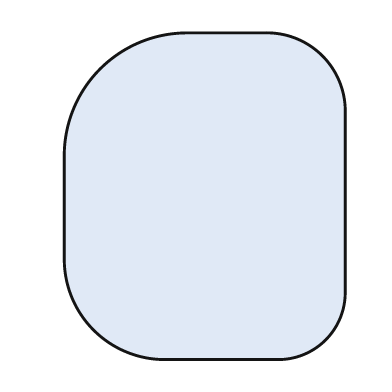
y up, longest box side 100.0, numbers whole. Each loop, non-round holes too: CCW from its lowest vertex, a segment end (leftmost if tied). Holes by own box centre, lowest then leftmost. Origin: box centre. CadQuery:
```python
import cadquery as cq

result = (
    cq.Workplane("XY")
    .moveTo(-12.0, -50.0)
    .lineTo(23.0, -50.0)
    .threePointArc((37.0, -44.0), (43.0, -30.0))
    .lineTo(43.0, 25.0)
    .threePointArc((36.0, 43.0), (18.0, 50.0))
    .lineTo(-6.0, 50.0)
    .threePointArc((-32.0, 39.0), (-43.0, 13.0))
    .lineTo(-43.0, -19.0)
    .threePointArc((-34.0, -41.0), (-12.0, -50.0))
    .close()
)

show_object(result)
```